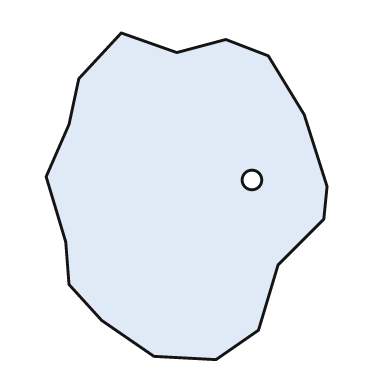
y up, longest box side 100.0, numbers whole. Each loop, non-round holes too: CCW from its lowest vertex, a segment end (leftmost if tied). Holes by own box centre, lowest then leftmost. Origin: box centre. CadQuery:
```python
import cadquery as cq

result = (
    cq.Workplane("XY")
    .moveTo(9.0, -50.0)
    .lineTo(22.0, -41.0)
    .lineTo(28.0, -21.0)
    .lineTo(42.0, -7.0)
    .lineTo(43.0, 3.0)
    .lineTo(36.0, 25.0)
    .lineTo(25.0, 43.0)
    .lineTo(12.0, 48.0)
    .lineTo(-3.0, 44.0)
    .lineTo(-20.0, 50.0)
    .lineTo(-33.0, 36.0)
    .lineTo(-36.0, 22.0)
    .lineTo(-43.0, 6.0)
    .lineTo(-37.0, -14.0)
    .lineTo(-36.0, -27.0)
    .lineTo(-26.0, -38.0)
    .lineTo(-10.0, -49.0)
    .close()
    .moveTo(20.0, 5.0)
    .circle(3.0)
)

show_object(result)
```